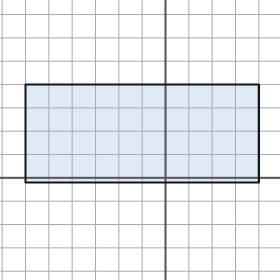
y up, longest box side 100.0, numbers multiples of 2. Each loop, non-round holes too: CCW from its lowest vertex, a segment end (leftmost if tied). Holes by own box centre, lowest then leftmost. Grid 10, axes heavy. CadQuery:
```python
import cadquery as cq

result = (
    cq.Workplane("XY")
    .moveTo(-60.0, -2.0)
    .lineTo(40.0, -2.0)
    .lineTo(40.0, 40.0)
    .lineTo(-60.0, 40.0)
    .close()
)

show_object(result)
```